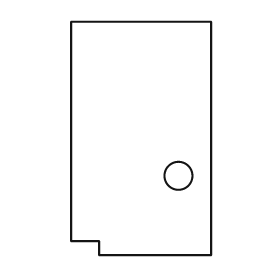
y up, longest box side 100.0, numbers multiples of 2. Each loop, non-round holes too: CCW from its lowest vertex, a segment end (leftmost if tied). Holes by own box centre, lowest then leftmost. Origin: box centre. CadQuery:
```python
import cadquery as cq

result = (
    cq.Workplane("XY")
    .moveTo(-18.0, -50.0)
    .lineTo(30.0, -50.0)
    .lineTo(30.0, 50.0)
    .lineTo(-30.0, 50.0)
    .lineTo(-30.0, -44.0)
    .lineTo(-18.0, -44.0)
    .close()
    .moveTo(16.0, -16.0)
    .circle(6.0)
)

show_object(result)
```